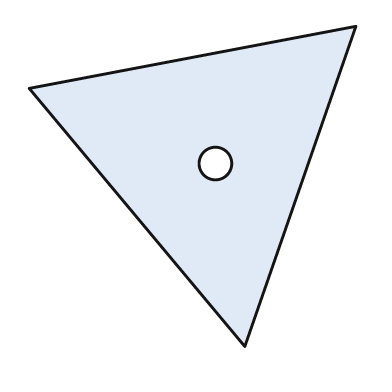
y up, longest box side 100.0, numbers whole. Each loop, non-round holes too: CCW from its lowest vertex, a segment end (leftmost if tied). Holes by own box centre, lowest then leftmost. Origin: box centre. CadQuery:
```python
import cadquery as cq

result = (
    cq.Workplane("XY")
    .moveTo(16.0, -49.0)
    .lineTo(50.0, 49.0)
    .lineTo(-50.0, 30.0)
    .close()
    .moveTo(7.0, 7.0)
    .circle(5.0)
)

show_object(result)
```